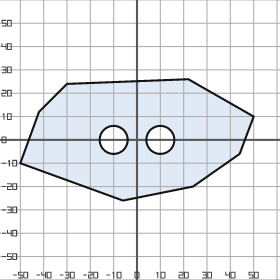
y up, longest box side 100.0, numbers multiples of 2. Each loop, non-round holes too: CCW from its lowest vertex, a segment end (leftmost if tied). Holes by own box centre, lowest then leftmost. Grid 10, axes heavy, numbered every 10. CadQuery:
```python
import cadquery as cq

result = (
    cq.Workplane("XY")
    .moveTo(-6.0, -26.0)
    .lineTo(24.0, -20.0)
    .lineTo(44.0, -6.0)
    .lineTo(50.0, 10.0)
    .lineTo(22.0, 26.0)
    .lineTo(-30.0, 24.0)
    .lineTo(-42.0, 12.0)
    .lineTo(-50.0, -10.0)
    .close()
    .moveTo(-10.0, 0.0)
    .circle(6.0)
    .moveTo(10.0, 0.0)
    .circle(6.0)
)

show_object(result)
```